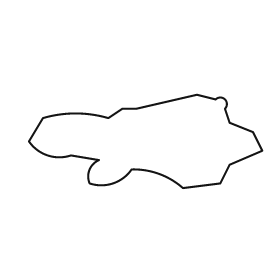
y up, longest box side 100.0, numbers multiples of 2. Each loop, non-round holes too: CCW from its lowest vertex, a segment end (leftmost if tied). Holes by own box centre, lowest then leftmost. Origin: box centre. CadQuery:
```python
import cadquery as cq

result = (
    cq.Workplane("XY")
    .moveTo(16.0, -20.0)
    .lineTo(32.0, -18.0)
    .lineTo(36.0, -10.0)
    .lineTo(50.0, -4.0)
    .lineTo(46.0, 4.0)
    .lineTo(36.0, 8.0)
    .lineTo(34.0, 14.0)
    .threePointArc((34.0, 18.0), (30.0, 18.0))
    .lineTo(22.0, 20.0)
    .lineTo(-4.0, 14.0)
    .lineTo(-10.0, 14.0)
    .lineTo(-16.0, 10.0)
    .threePointArc((-30.0, 12.0), (-44.0, 10.0))
    .lineTo(-50.0, 0.0)
    .threePointArc((-42.0, -6.0), (-32.0, -6.0))
    .lineTo(-20.0, -8.0)
    .threePointArc((-24.0, -12.0), (-24.0, -18.0))
    .threePointArc((-14.0, -18.0), (-6.0, -12.0))
    .threePointArc((6.0, -14.0), (16.0, -20.0))
    .close()
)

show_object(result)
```